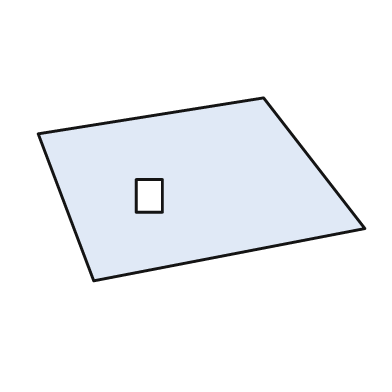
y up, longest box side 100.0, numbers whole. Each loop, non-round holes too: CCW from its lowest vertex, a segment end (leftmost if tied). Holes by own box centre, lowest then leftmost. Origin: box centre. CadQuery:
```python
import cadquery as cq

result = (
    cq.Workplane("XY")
    .moveTo(-33.0, -28.0)
    .lineTo(50.0, -12.0)
    .lineTo(19.0, 28.0)
    .lineTo(-50.0, 17.0)
    .close()
    .moveTo(-20.0, -7.0)
    .lineTo(-12.0, -7.0)
    .lineTo(-12.0, 3.0)
    .lineTo(-20.0, 3.0)
    .close()
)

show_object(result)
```